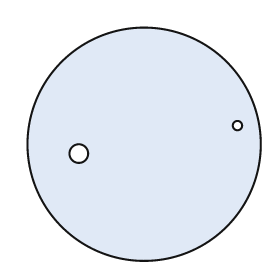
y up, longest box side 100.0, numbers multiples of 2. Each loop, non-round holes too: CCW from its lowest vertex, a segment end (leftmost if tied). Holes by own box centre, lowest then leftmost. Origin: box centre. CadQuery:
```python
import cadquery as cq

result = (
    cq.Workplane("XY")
    .moveTo(0.0, 0.0)
    .circle(50.0)
    .moveTo(-28.0, -4.0)
    .circle(4.0)
    .moveTo(40.0, 8.0)
    .circle(2.0)
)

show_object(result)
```